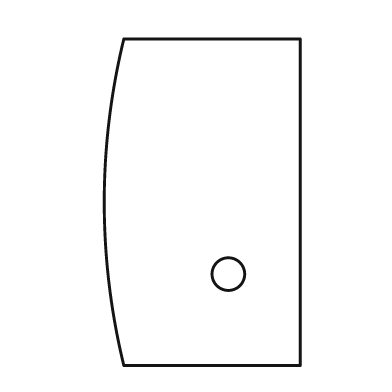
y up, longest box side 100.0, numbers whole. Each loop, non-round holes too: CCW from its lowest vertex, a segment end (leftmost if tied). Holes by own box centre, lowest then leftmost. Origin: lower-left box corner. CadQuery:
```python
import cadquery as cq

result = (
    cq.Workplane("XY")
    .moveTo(6.0, 0.0)
    .lineTo(60.0, 0.0)
    .lineTo(60.0, 100.0)
    .lineTo(6.0, 100.0)
    .threePointArc((0.0, 50.0), (6.0, 0.0))
    .close()
    .moveTo(38.0, 28.0)
    .circle(5.0)
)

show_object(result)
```